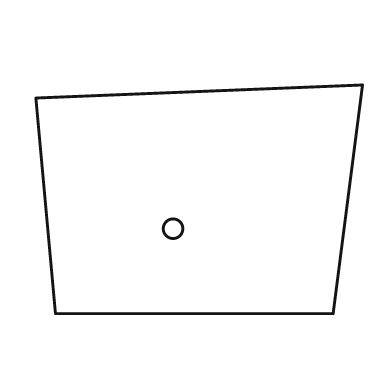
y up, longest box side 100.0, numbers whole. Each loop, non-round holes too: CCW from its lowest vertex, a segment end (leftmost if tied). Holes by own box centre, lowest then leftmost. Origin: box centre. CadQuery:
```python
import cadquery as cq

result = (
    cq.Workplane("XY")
    .moveTo(-44.0, -35.0)
    .lineTo(41.0, -35.0)
    .lineTo(50.0, 35.0)
    .lineTo(-50.0, 31.0)
    .close()
    .moveTo(-8.0, -9.0)
    .circle(3.0)
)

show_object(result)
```